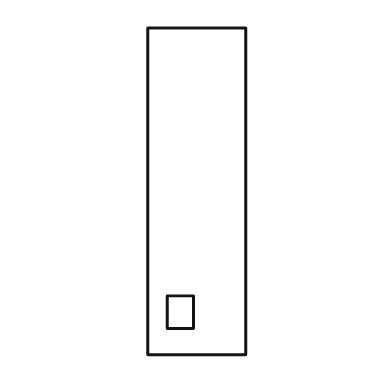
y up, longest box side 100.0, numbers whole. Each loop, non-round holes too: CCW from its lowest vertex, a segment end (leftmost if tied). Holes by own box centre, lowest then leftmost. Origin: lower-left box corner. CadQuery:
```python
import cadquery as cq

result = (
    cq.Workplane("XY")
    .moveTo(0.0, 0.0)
    .lineTo(30.0, 0.0)
    .lineTo(30.0, 100.0)
    .lineTo(0.0, 100.0)
    .close()
    .moveTo(6.0, 8.0)
    .lineTo(14.0, 8.0)
    .lineTo(14.0, 18.0)
    .lineTo(6.0, 18.0)
    .close()
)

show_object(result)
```